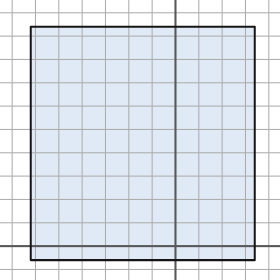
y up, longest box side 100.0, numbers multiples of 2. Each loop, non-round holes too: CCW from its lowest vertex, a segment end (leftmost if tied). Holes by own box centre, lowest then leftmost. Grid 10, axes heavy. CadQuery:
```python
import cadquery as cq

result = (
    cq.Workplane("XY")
    .moveTo(-62.0, -6.0)
    .lineTo(34.0, -6.0)
    .lineTo(34.0, 94.0)
    .lineTo(-62.0, 94.0)
    .close()
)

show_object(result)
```